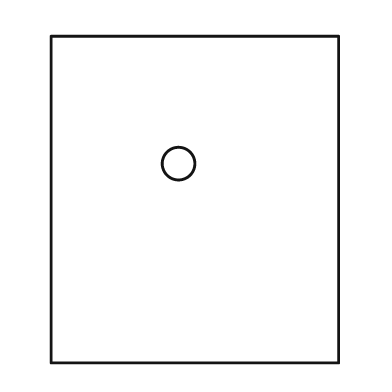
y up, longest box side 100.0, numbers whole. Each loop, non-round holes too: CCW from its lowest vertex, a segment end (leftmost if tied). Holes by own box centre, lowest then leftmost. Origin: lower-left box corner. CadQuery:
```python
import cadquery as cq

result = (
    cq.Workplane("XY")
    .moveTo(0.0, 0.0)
    .lineTo(88.0, 0.0)
    .lineTo(88.0, 100.0)
    .lineTo(0.0, 100.0)
    .close()
    .moveTo(39.0, 61.0)
    .circle(5.0)
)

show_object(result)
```